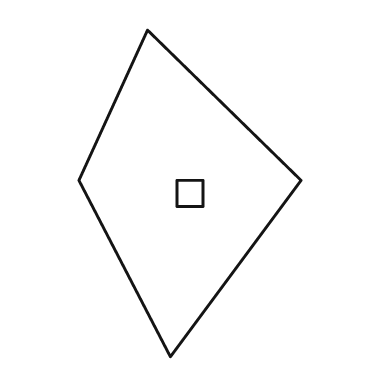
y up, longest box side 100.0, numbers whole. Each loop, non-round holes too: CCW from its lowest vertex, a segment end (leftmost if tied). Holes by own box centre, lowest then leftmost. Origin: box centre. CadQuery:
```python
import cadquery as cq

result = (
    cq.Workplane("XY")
    .moveTo(-6.0, -50.0)
    .lineTo(34.0, 4.0)
    .lineTo(-13.0, 50.0)
    .lineTo(-34.0, 4.0)
    .close()
    .moveTo(-4.0, -4.0)
    .lineTo(4.0, -4.0)
    .lineTo(4.0, 4.0)
    .lineTo(-4.0, 4.0)
    .close()
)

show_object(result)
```